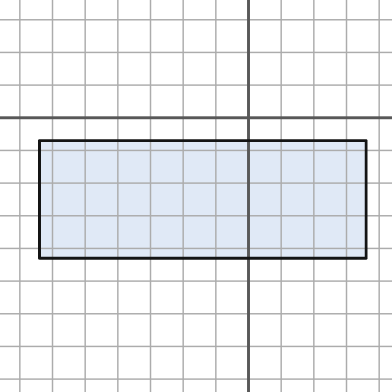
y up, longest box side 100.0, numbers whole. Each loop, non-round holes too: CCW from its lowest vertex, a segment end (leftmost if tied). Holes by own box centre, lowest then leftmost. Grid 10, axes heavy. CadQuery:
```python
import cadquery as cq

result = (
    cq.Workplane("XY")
    .moveTo(-64.0, -43.0)
    .lineTo(36.0, -43.0)
    .lineTo(36.0, -7.0)
    .lineTo(-64.0, -7.0)
    .close()
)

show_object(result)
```